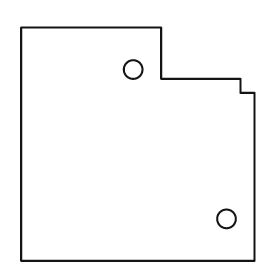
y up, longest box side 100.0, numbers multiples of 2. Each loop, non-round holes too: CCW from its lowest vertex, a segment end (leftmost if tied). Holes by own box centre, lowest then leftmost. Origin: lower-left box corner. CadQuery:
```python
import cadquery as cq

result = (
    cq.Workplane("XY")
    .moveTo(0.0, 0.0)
    .lineTo(100.0, 0.0)
    .lineTo(100.0, 72.0)
    .lineTo(94.0, 72.0)
    .lineTo(94.0, 78.0)
    .lineTo(60.0, 78.0)
    .lineTo(60.0, 100.0)
    .lineTo(0.0, 100.0)
    .close()
    .moveTo(88.0, 18.0)
    .circle(4.0)
    .moveTo(48.0, 82.0)
    .circle(4.0)
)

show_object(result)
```